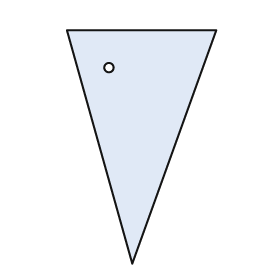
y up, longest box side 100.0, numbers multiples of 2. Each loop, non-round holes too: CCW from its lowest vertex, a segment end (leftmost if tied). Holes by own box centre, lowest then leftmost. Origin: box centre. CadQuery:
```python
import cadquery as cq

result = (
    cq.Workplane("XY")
    .moveTo(-4.0, -50.0)
    .lineTo(32.0, 50.0)
    .lineTo(-32.0, 50.0)
    .close()
    .moveTo(-14.0, 34.0)
    .circle(2.0)
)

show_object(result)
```